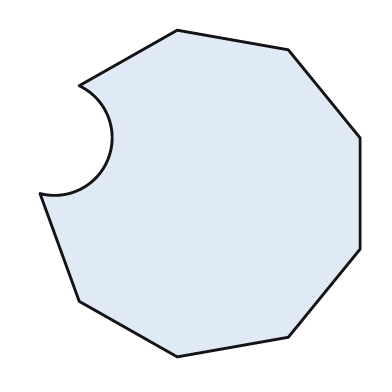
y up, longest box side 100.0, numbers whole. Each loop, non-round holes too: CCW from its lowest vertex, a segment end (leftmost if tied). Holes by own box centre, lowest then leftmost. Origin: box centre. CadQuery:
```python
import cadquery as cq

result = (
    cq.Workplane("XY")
    .moveTo(-7.0, -50.0)
    .lineTo(27.0, -44.0)
    .lineTo(49.0, -17.0)
    .lineTo(49.0, 17.0)
    .lineTo(27.0, 44.0)
    .lineTo(-7.0, 50.0)
    .lineTo(-37.0, 33.0)
    .threePointArc((-28.0, 11.0), (-49.0, 0.0))
    .lineTo(-37.0, -33.0)
    .close()
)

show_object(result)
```